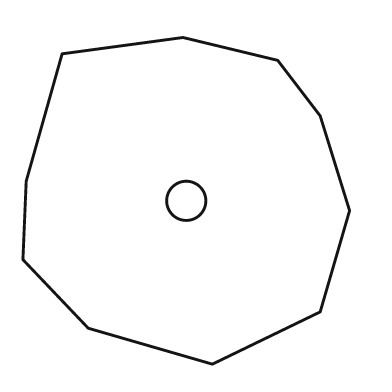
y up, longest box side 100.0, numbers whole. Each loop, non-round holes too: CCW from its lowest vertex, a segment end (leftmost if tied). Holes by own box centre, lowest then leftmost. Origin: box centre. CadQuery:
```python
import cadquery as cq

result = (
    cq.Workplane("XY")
    .moveTo(8.0, -50.0)
    .lineTo(41.0, -34.0)
    .lineTo(50.0, -3.0)
    .lineTo(41.0, 26.0)
    .lineTo(28.0, 43.0)
    .lineTo(-1.0, 50.0)
    .lineTo(-38.0, 45.0)
    .lineTo(-49.0, 6.0)
    .lineTo(-50.0, -18.0)
    .lineTo(-30.0, -39.0)
    .close()
    .moveTo(0.0, 0.0)
    .circle(6.0)
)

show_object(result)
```